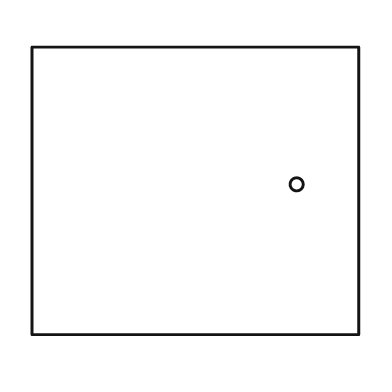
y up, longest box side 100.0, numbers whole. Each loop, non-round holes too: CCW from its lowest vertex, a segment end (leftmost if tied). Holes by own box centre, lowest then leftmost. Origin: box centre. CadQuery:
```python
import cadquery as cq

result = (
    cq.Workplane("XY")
    .moveTo(-50.0, -44.0)
    .lineTo(50.0, -44.0)
    .lineTo(50.0, 44.0)
    .lineTo(-50.0, 44.0)
    .close()
    .moveTo(31.0, 2.0)
    .circle(2.0)
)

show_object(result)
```